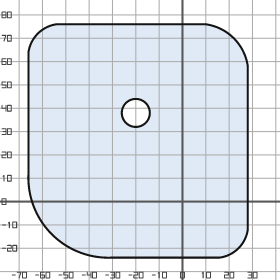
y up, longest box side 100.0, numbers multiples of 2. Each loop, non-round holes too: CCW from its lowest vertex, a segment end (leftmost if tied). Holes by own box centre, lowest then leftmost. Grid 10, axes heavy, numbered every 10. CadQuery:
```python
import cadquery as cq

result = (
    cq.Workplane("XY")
    .moveTo(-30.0, -24.0)
    .lineTo(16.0, -24.0)
    .threePointArc((24.0, -20.0), (28.0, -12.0))
    .lineTo(28.0, 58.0)
    .threePointArc((22.0, 70.0), (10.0, 76.0))
    .lineTo(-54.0, 76.0)
    .threePointArc((-62.0, 72.0), (-66.0, 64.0))
    .lineTo(-66.0, 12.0)
    .threePointArc((-56.0, -14.0), (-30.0, -24.0))
    .close()
    .moveTo(-20.0, 38.0)
    .circle(6.0)
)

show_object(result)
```